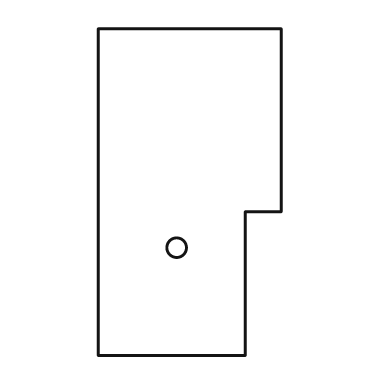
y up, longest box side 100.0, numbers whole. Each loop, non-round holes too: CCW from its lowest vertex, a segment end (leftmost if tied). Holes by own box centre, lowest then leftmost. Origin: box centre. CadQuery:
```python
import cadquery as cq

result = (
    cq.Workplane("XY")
    .moveTo(-28.0, -50.0)
    .lineTo(17.0, -50.0)
    .lineTo(17.0, -6.0)
    .lineTo(28.0, -6.0)
    .lineTo(28.0, 50.0)
    .lineTo(-28.0, 50.0)
    .close()
    .moveTo(-4.0, -17.0)
    .circle(3.0)
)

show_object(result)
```